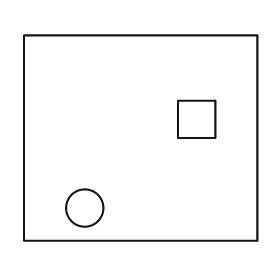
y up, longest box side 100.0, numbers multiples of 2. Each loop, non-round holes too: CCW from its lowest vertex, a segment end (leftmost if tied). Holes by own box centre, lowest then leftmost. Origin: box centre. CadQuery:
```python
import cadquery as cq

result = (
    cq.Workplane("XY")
    .moveTo(-50.0, -44.0)
    .lineTo(50.0, -44.0)
    .lineTo(50.0, 44.0)
    .lineTo(-50.0, 44.0)
    .close()
    .moveTo(-24.0, -30.0)
    .circle(8.0)
    .moveTo(16.0, 0.0)
    .lineTo(32.0, 0.0)
    .lineTo(32.0, 16.0)
    .lineTo(16.0, 16.0)
    .close()
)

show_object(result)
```